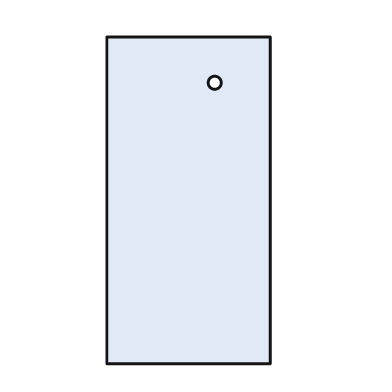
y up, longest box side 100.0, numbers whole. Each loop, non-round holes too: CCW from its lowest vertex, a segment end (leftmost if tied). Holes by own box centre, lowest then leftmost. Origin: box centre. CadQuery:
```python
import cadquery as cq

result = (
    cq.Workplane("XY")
    .moveTo(-25.0, -50.0)
    .lineTo(25.0, -50.0)
    .lineTo(25.0, 50.0)
    .lineTo(-25.0, 50.0)
    .close()
    .moveTo(8.0, 36.0)
    .circle(2.0)
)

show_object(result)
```